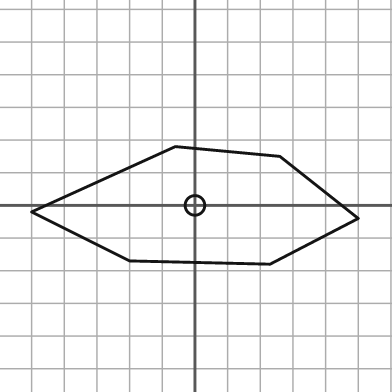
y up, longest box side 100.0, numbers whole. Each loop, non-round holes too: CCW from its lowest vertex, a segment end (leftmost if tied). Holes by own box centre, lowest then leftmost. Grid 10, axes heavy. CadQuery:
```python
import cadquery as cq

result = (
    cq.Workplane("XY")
    .moveTo(23.0, -18.0)
    .lineTo(50.0, -4.0)
    .lineTo(26.0, 15.0)
    .lineTo(-6.0, 18.0)
    .lineTo(-50.0, -2.0)
    .lineTo(-20.0, -17.0)
    .close()
    .moveTo(0.0, 0.0)
    .circle(3.0)
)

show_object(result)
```